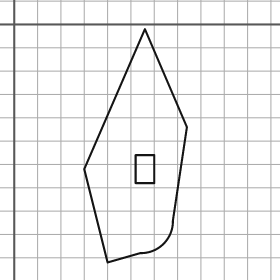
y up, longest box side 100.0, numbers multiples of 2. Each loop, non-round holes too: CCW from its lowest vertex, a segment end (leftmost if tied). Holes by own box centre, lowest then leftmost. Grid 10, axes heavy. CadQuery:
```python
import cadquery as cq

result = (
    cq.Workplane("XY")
    .moveTo(40.0, -102.0)
    .lineTo(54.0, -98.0)
    .threePointArc((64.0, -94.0), (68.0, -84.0))
    .lineTo(74.0, -44.0)
    .lineTo(56.0, -2.0)
    .lineTo(30.0, -62.0)
    .close()
    .moveTo(52.0, -68.0)
    .lineTo(60.0, -68.0)
    .lineTo(60.0, -56.0)
    .lineTo(52.0, -56.0)
    .close()
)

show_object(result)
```